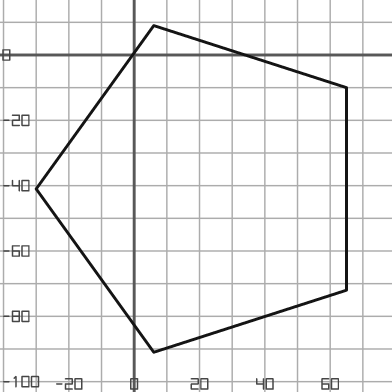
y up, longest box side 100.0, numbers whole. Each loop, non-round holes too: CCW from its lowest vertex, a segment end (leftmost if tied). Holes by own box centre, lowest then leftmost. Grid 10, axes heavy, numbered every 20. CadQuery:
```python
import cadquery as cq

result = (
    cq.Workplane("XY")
    .moveTo(6.0, -91.0)
    .lineTo(65.0, -72.0)
    .lineTo(65.0, -10.0)
    .lineTo(6.0, 9.0)
    .lineTo(-30.0, -41.0)
    .close()
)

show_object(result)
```